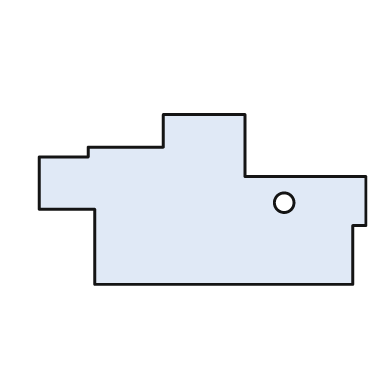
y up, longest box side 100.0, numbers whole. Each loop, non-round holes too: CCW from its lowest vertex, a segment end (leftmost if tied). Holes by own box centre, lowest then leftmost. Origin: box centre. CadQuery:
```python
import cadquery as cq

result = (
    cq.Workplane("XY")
    .moveTo(-33.0, -26.0)
    .lineTo(46.0, -26.0)
    .lineTo(46.0, -8.0)
    .lineTo(50.0, -8.0)
    .lineTo(50.0, 7.0)
    .lineTo(13.0, 7.0)
    .lineTo(13.0, 26.0)
    .lineTo(-12.0, 26.0)
    .lineTo(-12.0, 16.0)
    .lineTo(-35.0, 16.0)
    .lineTo(-35.0, 13.0)
    .lineTo(-50.0, 13.0)
    .lineTo(-50.0, -3.0)
    .lineTo(-33.0, -3.0)
    .close()
    .moveTo(25.0, -1.0)
    .circle(3.0)
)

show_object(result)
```